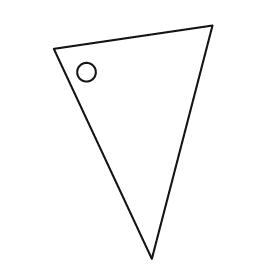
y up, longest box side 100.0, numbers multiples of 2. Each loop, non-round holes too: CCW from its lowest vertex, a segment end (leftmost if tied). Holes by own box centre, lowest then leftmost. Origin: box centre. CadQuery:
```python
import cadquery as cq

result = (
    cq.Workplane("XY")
    .moveTo(8.0, -50.0)
    .lineTo(34.0, 50.0)
    .lineTo(-34.0, 40.0)
    .close()
    .moveTo(-20.0, 30.0)
    .circle(4.0)
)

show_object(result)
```